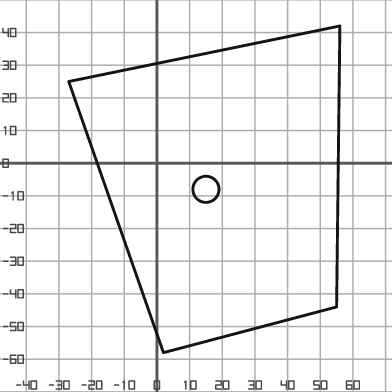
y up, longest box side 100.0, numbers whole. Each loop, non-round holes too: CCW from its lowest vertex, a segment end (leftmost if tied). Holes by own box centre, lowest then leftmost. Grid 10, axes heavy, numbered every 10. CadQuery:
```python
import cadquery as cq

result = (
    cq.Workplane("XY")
    .moveTo(2.0, -58.0)
    .lineTo(55.0, -44.0)
    .lineTo(56.0, 42.0)
    .lineTo(-27.0, 25.0)
    .close()
    .moveTo(15.0, -8.0)
    .circle(4.0)
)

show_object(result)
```